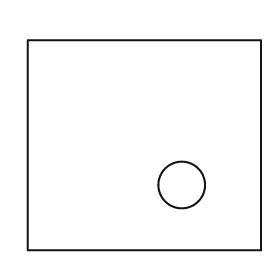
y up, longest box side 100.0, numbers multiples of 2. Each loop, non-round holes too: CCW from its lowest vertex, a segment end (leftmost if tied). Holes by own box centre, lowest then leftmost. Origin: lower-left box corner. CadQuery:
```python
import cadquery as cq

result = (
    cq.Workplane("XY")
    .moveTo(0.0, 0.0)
    .lineTo(100.0, 0.0)
    .lineTo(100.0, 90.0)
    .lineTo(0.0, 90.0)
    .close()
    .moveTo(66.0, 28.0)
    .circle(10.0)
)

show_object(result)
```